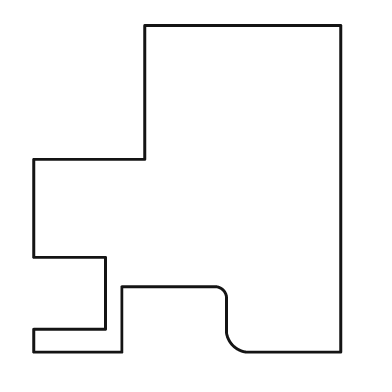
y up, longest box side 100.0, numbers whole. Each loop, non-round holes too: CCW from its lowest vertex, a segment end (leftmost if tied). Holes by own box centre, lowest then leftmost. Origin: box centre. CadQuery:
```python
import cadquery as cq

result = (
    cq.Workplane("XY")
    .moveTo(-47.0, -50.0)
    .lineTo(-20.0, -50.0)
    .lineTo(-20.0, -30.0)
    .lineTo(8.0, -30.0)
    .threePointArc((11.0, -31.0), (12.0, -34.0))
    .lineTo(12.0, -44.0)
    .threePointArc((14.0, -48.0), (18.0, -50.0))
    .lineTo(47.0, -50.0)
    .lineTo(47.0, 50.0)
    .lineTo(-13.0, 50.0)
    .lineTo(-13.0, 9.0)
    .lineTo(-47.0, 9.0)
    .lineTo(-47.0, -21.0)
    .lineTo(-25.0, -21.0)
    .lineTo(-25.0, -43.0)
    .lineTo(-47.0, -43.0)
    .close()
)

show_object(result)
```